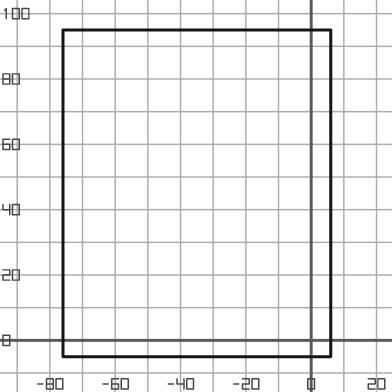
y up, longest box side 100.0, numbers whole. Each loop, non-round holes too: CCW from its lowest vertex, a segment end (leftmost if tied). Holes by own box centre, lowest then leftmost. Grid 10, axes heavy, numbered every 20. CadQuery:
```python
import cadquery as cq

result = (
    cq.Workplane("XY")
    .moveTo(-76.0, -5.0)
    .lineTo(6.0, -5.0)
    .lineTo(6.0, 95.0)
    .lineTo(-76.0, 95.0)
    .close()
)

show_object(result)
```